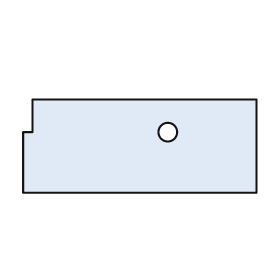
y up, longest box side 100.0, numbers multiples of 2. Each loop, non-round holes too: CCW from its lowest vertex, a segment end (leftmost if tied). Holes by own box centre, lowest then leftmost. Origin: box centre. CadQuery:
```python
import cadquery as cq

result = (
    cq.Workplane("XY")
    .moveTo(-50.0, -20.0)
    .lineTo(50.0, -20.0)
    .lineTo(50.0, 20.0)
    .lineTo(-46.0, 20.0)
    .lineTo(-46.0, 6.0)
    .lineTo(-50.0, 6.0)
    .close()
    .moveTo(12.0, 6.0)
    .circle(4.0)
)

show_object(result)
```